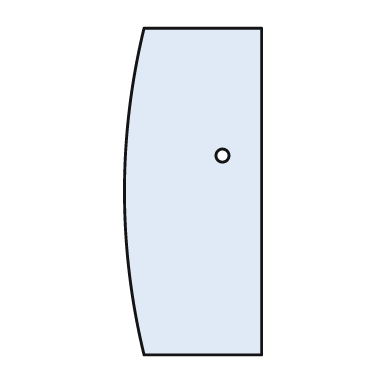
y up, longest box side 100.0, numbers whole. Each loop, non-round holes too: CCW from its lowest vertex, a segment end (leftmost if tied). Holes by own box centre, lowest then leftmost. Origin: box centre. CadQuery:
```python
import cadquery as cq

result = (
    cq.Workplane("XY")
    .moveTo(-15.0, -50.0)
    .lineTo(21.0, -50.0)
    .lineTo(21.0, 50.0)
    .lineTo(-15.0, 50.0)
    .threePointArc((-21.0, 0.0), (-15.0, -50.0))
    .close()
    .moveTo(9.0, 11.0)
    .circle(2.0)
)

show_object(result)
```